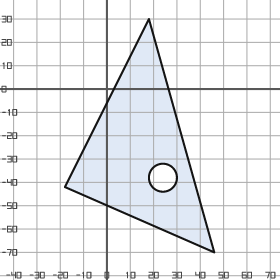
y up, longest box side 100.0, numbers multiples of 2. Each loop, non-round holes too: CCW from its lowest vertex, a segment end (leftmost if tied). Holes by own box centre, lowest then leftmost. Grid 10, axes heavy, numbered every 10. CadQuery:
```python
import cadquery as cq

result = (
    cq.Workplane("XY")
    .moveTo(46.0, -70.0)
    .lineTo(18.0, 30.0)
    .lineTo(-18.0, -42.0)
    .close()
    .moveTo(24.0, -38.0)
    .circle(6.0)
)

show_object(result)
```